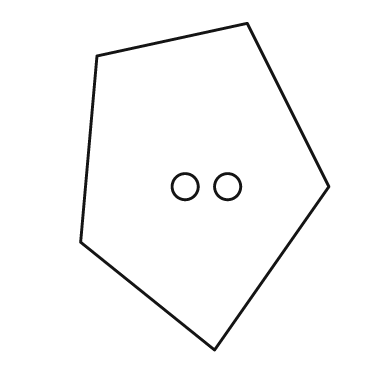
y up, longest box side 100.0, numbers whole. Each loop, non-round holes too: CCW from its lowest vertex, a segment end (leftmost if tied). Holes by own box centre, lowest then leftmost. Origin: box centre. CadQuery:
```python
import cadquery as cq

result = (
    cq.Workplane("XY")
    .moveTo(3.0, -50.0)
    .lineTo(38.0, 0.0)
    .lineTo(13.0, 50.0)
    .lineTo(-33.0, 40.0)
    .lineTo(-38.0, -17.0)
    .close()
    .moveTo(-6.0, 0.0)
    .circle(4.0)
    .moveTo(7.0, 0.0)
    .circle(4.0)
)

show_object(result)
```